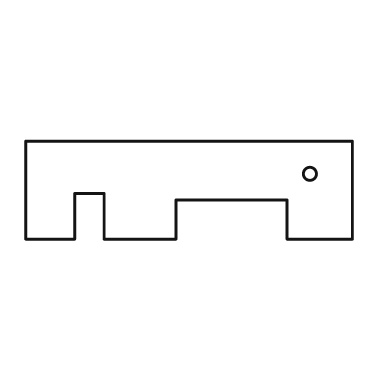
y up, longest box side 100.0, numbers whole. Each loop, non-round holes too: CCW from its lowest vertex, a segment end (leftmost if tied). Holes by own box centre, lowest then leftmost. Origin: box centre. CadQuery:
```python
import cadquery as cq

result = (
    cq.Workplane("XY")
    .moveTo(-50.0, -15.0)
    .lineTo(-35.0, -15.0)
    .lineTo(-35.0, -1.0)
    .lineTo(-26.0, -1.0)
    .lineTo(-26.0, -15.0)
    .lineTo(-4.0, -15.0)
    .lineTo(-4.0, -3.0)
    .lineTo(30.0, -3.0)
    .lineTo(30.0, -15.0)
    .lineTo(50.0, -15.0)
    .lineTo(50.0, 15.0)
    .lineTo(-50.0, 15.0)
    .close()
    .moveTo(37.0, 5.0)
    .circle(2.0)
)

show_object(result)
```